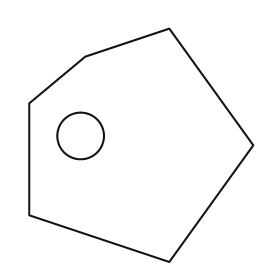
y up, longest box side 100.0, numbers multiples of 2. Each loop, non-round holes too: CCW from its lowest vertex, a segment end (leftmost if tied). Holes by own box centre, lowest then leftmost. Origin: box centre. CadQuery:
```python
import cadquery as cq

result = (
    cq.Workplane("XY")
    .moveTo(12.0, -50.0)
    .lineTo(48.0, 0.0)
    .lineTo(12.0, 50.0)
    .lineTo(-24.0, 38.0)
    .lineTo(-48.0, 18.0)
    .lineTo(-48.0, -30.0)
    .close()
    .moveTo(-26.0, 4.0)
    .circle(10.0)
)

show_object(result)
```